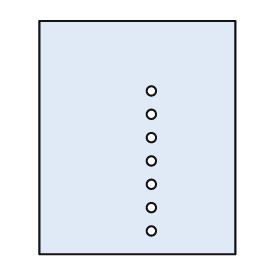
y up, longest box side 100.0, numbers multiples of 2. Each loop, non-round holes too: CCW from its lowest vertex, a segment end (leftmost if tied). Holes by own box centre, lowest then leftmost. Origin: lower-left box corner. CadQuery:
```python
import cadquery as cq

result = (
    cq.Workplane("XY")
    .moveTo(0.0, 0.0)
    .lineTo(84.0, 0.0)
    .lineTo(84.0, 100.0)
    .lineTo(0.0, 100.0)
    .close()
    .moveTo(48.0, 10.0)
    .circle(2.0)
    .moveTo(48.0, 20.0)
    .circle(2.0)
    .moveTo(48.0, 30.0)
    .circle(2.0)
    .moveTo(48.0, 40.0)
    .circle(2.0)
    .moveTo(48.0, 50.0)
    .circle(2.0)
    .moveTo(48.0, 60.0)
    .circle(2.0)
    .moveTo(48.0, 70.0)
    .circle(2.0)
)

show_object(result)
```